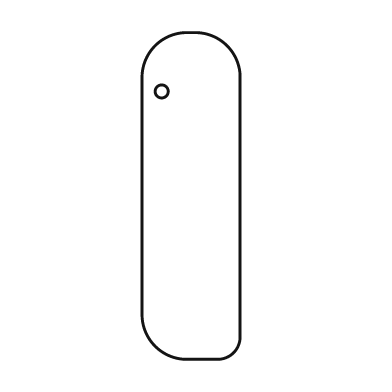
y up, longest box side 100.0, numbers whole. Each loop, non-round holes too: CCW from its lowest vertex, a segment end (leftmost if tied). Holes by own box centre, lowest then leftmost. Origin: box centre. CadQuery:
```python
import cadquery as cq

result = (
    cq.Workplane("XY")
    .moveTo(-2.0, -50.0)
    .lineTo(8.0, -50.0)
    .threePointArc((13.0, -48.0), (15.0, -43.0))
    .lineTo(15.0, 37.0)
    .threePointArc((11.0, 46.0), (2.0, 50.0))
    .lineTo(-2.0, 50.0)
    .threePointArc((-11.0, 46.0), (-15.0, 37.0))
    .lineTo(-15.0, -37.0)
    .threePointArc((-11.0, -46.0), (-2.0, -50.0))
    .close()
    .moveTo(-9.0, 32.0)
    .circle(2.0)
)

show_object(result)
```